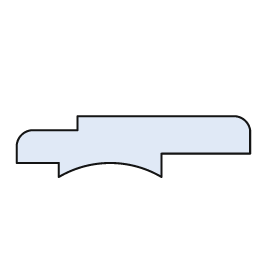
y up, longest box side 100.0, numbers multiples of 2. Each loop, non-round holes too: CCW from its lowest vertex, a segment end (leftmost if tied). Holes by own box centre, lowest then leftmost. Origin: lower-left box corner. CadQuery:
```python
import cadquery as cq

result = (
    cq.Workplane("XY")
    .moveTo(18.0, 0.0)
    .threePointArc((40.0, 6.0), (62.0, 0.0))
    .lineTo(62.0, 10.0)
    .lineTo(100.0, 10.0)
    .lineTo(100.0, 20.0)
    .threePointArc((98.0, 24.0), (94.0, 26.0))
    .lineTo(26.0, 26.0)
    .lineTo(26.0, 20.0)
    .lineTo(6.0, 20.0)
    .threePointArc((2.0, 18.0), (0.0, 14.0))
    .lineTo(0.0, 6.0)
    .lineTo(18.0, 6.0)
    .close()
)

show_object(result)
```